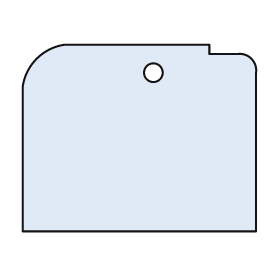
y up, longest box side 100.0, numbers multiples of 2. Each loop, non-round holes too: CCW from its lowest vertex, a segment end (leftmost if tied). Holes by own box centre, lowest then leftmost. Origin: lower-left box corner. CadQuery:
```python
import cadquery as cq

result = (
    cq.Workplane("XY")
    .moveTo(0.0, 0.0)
    .lineTo(100.0, 0.0)
    .lineTo(100.0, 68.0)
    .threePointArc((98.0, 74.0), (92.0, 76.0))
    .lineTo(80.0, 76.0)
    .lineTo(80.0, 80.0)
    .lineTo(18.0, 80.0)
    .threePointArc((6.0, 74.0), (0.0, 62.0))
    .close()
    .moveTo(56.0, 68.0)
    .circle(4.0)
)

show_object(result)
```